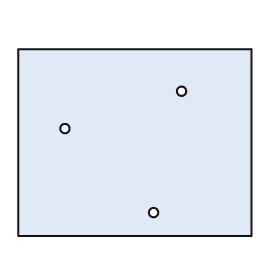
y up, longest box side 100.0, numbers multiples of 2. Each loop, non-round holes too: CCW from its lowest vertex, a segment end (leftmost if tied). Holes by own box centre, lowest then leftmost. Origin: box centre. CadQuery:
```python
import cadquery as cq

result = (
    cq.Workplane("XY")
    .moveTo(-50.0, -40.0)
    .lineTo(50.0, -40.0)
    .lineTo(50.0, 40.0)
    .lineTo(-50.0, 40.0)
    .close()
    .moveTo(8.0, -30.0)
    .circle(2.0)
    .moveTo(-30.0, 6.0)
    .circle(2.0)
    .moveTo(20.0, 22.0)
    .circle(2.0)
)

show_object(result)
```